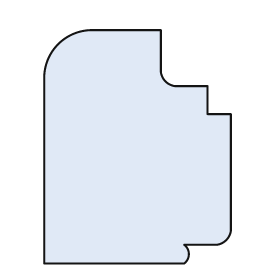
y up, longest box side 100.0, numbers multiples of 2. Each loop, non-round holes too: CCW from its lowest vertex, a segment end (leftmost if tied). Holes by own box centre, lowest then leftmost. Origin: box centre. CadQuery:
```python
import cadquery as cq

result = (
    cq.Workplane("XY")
    .moveTo(-40.0, -50.0)
    .lineTo(20.0, -50.0)
    .threePointArc((22.0, -46.0), (20.0, -42.0))
    .lineTo(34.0, -42.0)
    .threePointArc((38.0, -40.0), (40.0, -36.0))
    .lineTo(40.0, 14.0)
    .lineTo(30.0, 14.0)
    .lineTo(30.0, 26.0)
    .lineTo(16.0, 26.0)
    .threePointArc((12.0, 28.0), (10.0, 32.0))
    .lineTo(10.0, 50.0)
    .lineTo(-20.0, 50.0)
    .threePointArc((-34.0, 44.0), (-40.0, 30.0))
    .close()
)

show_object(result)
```